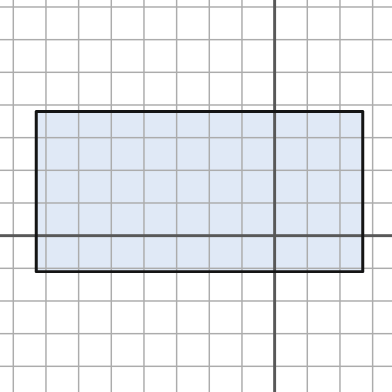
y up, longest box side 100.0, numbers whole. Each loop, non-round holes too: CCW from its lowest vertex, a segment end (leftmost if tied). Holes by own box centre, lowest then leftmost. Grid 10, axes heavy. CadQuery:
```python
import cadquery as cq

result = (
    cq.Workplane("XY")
    .moveTo(-73.0, -11.0)
    .lineTo(27.0, -11.0)
    .lineTo(27.0, 38.0)
    .lineTo(-73.0, 38.0)
    .close()
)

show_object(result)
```